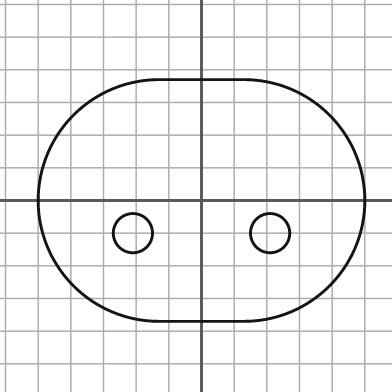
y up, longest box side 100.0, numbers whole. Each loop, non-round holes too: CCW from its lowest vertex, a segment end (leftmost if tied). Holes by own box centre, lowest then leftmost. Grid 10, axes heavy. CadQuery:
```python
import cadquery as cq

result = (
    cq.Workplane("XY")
    .moveTo(-13.0, -37.0)
    .lineTo(13.0, -37.0)
    .threePointArc((50.0, 0.0), (13.0, 37.0))
    .lineTo(-13.0, 37.0)
    .threePointArc((-50.0, 0.0), (-13.0, -37.0))
    .close()
    .moveTo(-21.0, -10.0)
    .circle(6.0)
    .moveTo(21.0, -10.0)
    .circle(6.0)
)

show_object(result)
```